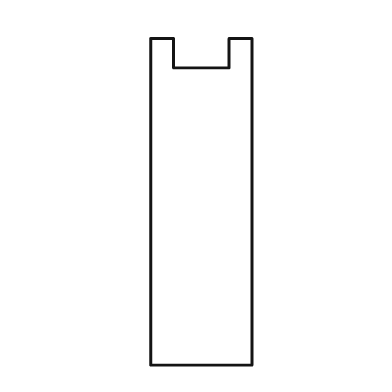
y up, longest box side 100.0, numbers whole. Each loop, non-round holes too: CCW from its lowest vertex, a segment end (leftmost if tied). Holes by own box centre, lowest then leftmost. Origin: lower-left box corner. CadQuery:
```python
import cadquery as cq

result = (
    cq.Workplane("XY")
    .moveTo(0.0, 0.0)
    .lineTo(31.0, 0.0)
    .lineTo(31.0, 100.0)
    .lineTo(24.0, 100.0)
    .lineTo(24.0, 91.0)
    .lineTo(7.0, 91.0)
    .lineTo(7.0, 100.0)
    .lineTo(0.0, 100.0)
    .close()
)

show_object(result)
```